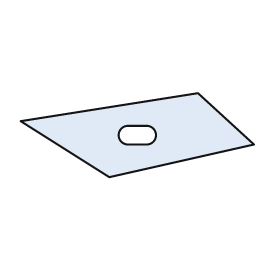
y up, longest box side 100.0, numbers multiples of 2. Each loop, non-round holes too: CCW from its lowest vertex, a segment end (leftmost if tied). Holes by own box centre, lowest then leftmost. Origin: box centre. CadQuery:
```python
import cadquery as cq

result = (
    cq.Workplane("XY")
    .moveTo(-12.0, -18.0)
    .lineTo(50.0, -4.0)
    .lineTo(26.0, 18.0)
    .lineTo(-50.0, 6.0)
    .close()
    .moveTo(-4.0, -4.0)
    .lineTo(4.0, -4.0)
    .threePointArc((8.0, 0.0), (4.0, 4.0))
    .lineTo(-4.0, 4.0)
    .threePointArc((-8.0, 0.0), (-4.0, -4.0))
    .close()
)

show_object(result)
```